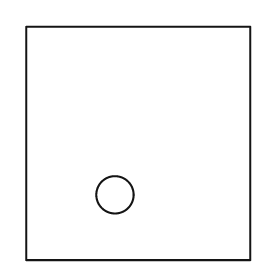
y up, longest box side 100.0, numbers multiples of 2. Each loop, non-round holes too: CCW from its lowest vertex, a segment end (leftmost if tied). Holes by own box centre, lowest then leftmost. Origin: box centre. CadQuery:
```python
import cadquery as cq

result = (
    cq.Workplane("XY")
    .moveTo(-48.0, -50.0)
    .lineTo(48.0, -50.0)
    .lineTo(48.0, 50.0)
    .lineTo(-48.0, 50.0)
    .close()
    .moveTo(-10.0, -22.0)
    .circle(8.0)
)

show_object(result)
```